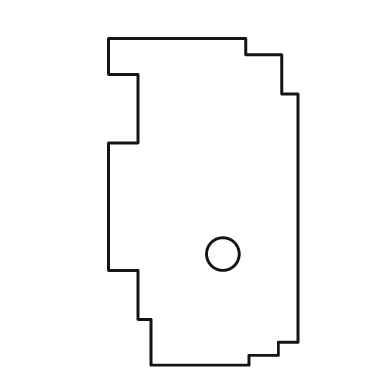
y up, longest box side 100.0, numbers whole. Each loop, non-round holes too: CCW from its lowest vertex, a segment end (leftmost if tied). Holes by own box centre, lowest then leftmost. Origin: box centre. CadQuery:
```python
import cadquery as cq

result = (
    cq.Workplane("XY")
    .moveTo(-16.0, -50.0)
    .lineTo(14.0, -50.0)
    .lineTo(14.0, -47.0)
    .lineTo(23.0, -47.0)
    .lineTo(23.0, -43.0)
    .lineTo(29.0, -43.0)
    .lineTo(29.0, 33.0)
    .lineTo(24.0, 33.0)
    .lineTo(24.0, 45.0)
    .lineTo(13.0, 45.0)
    .lineTo(13.0, 50.0)
    .lineTo(-29.0, 50.0)
    .lineTo(-29.0, 39.0)
    .lineTo(-20.0, 39.0)
    .lineTo(-20.0, 18.0)
    .lineTo(-29.0, 18.0)
    .lineTo(-29.0, -21.0)
    .lineTo(-20.0, -21.0)
    .lineTo(-20.0, -36.0)
    .lineTo(-16.0, -36.0)
    .close()
    .moveTo(6.0, -16.0)
    .circle(5.0)
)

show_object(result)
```